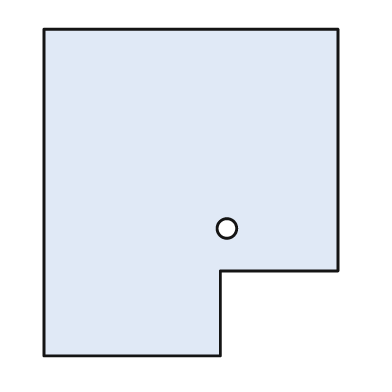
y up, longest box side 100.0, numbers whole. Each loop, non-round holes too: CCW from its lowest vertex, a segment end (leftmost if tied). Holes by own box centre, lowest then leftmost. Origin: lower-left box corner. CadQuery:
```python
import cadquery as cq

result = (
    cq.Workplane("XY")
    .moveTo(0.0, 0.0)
    .lineTo(54.0, 0.0)
    .lineTo(54.0, 26.0)
    .lineTo(90.0, 26.0)
    .lineTo(90.0, 100.0)
    .lineTo(0.0, 100.0)
    .close()
    .moveTo(56.0, 39.0)
    .circle(3.0)
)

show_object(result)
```